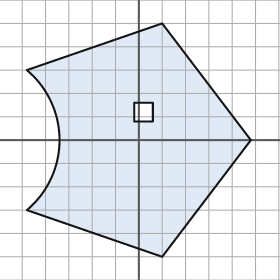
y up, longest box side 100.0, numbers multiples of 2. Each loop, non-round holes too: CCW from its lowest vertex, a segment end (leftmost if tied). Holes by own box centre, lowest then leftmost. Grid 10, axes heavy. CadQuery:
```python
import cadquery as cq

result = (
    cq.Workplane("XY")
    .moveTo(10.0, -50.0)
    .lineTo(48.0, 0.0)
    .lineTo(10.0, 50.0)
    .lineTo(-48.0, 30.0)
    .threePointArc((-34.0, 0.0), (-48.0, -30.0))
    .close()
    .moveTo(-2.0, 8.0)
    .lineTo(6.0, 8.0)
    .lineTo(6.0, 16.0)
    .lineTo(-2.0, 16.0)
    .close()
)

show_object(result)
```